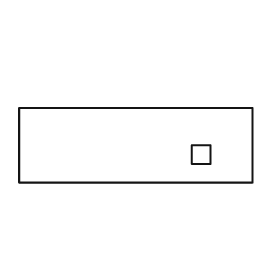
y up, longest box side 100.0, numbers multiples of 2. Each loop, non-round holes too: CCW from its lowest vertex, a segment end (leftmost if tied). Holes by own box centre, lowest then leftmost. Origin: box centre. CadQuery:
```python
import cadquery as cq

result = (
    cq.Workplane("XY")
    .moveTo(-50.0, -16.0)
    .lineTo(50.0, -16.0)
    .lineTo(50.0, 16.0)
    .lineTo(-50.0, 16.0)
    .close()
    .moveTo(24.0, -8.0)
    .lineTo(32.0, -8.0)
    .lineTo(32.0, 0.0)
    .lineTo(24.0, 0.0)
    .close()
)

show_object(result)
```